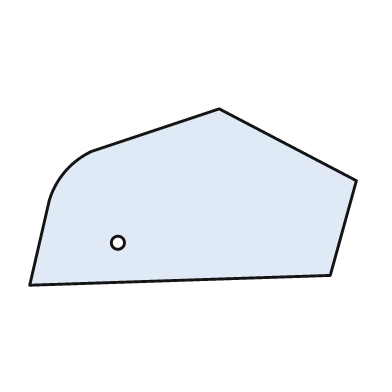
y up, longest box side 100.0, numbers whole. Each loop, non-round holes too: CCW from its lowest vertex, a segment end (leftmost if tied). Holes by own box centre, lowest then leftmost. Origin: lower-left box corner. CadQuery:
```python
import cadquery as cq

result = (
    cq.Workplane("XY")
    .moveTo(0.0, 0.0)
    .lineTo(92.0, 3.0)
    .lineTo(100.0, 32.0)
    .lineTo(58.0, 54.0)
    .lineTo(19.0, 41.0)
    .threePointArc((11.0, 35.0), (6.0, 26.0))
    .close()
    .moveTo(27.0, 13.0)
    .circle(2.0)
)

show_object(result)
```